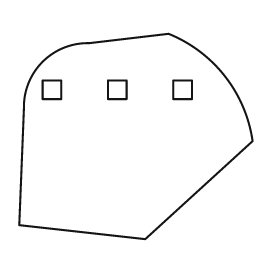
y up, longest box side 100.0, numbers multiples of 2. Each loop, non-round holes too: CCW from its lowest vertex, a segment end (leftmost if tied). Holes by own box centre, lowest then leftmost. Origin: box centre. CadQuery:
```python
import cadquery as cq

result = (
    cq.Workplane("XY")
    .moveTo(4.0, -44.0)
    .lineTo(50.0, -2.0)
    .threePointArc((38.0, 26.0), (14.0, 44.0))
    .lineTo(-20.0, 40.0)
    .threePointArc((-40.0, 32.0), (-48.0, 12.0))
    .lineTo(-50.0, -38.0)
    .close()
    .moveTo(-40.0, 16.0)
    .lineTo(-32.0, 16.0)
    .lineTo(-32.0, 24.0)
    .lineTo(-40.0, 24.0)
    .close()
    .moveTo(-12.0, 16.0)
    .lineTo(-4.0, 16.0)
    .lineTo(-4.0, 24.0)
    .lineTo(-12.0, 24.0)
    .close()
    .moveTo(16.0, 16.0)
    .lineTo(24.0, 16.0)
    .lineTo(24.0, 24.0)
    .lineTo(16.0, 24.0)
    .close()
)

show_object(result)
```